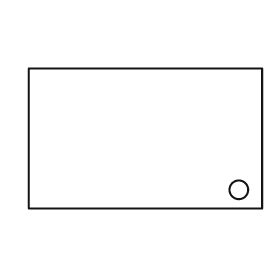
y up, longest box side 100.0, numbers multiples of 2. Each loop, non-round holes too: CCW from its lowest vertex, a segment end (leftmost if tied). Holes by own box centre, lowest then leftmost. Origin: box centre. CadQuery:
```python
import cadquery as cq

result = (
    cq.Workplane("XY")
    .moveTo(-50.0, -30.0)
    .lineTo(50.0, -30.0)
    .lineTo(50.0, 30.0)
    .lineTo(-50.0, 30.0)
    .close()
    .moveTo(40.0, -22.0)
    .circle(4.0)
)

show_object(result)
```